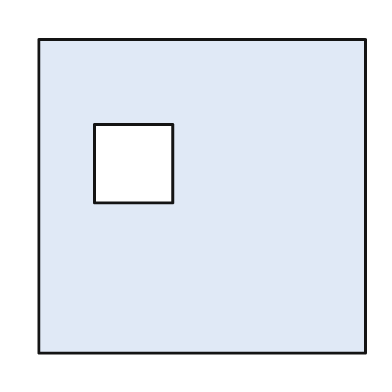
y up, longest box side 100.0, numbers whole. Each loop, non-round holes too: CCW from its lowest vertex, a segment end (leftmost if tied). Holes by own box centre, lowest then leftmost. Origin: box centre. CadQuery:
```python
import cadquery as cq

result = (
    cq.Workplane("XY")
    .moveTo(-50.0, -48.0)
    .lineTo(50.0, -48.0)
    .lineTo(50.0, 48.0)
    .lineTo(-50.0, 48.0)
    .close()
    .moveTo(-33.0, -2.0)
    .lineTo(-9.0, -2.0)
    .lineTo(-9.0, 22.0)
    .lineTo(-33.0, 22.0)
    .close()
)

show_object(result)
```